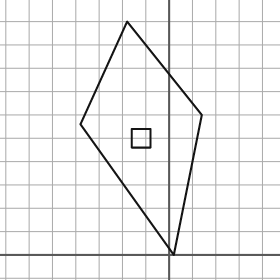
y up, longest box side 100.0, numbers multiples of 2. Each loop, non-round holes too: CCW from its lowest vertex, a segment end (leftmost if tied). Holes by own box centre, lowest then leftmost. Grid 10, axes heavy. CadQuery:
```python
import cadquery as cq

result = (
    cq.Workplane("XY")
    .moveTo(2.0, 0.0)
    .lineTo(14.0, 60.0)
    .lineTo(-18.0, 100.0)
    .lineTo(-38.0, 56.0)
    .close()
    .moveTo(-16.0, 46.0)
    .lineTo(-8.0, 46.0)
    .lineTo(-8.0, 54.0)
    .lineTo(-16.0, 54.0)
    .close()
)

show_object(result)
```